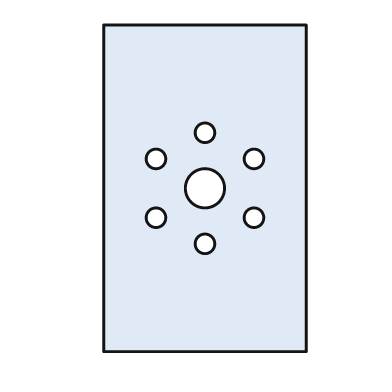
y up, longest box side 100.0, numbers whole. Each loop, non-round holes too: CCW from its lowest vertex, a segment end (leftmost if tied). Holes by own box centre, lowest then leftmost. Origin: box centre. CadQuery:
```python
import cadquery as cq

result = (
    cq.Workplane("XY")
    .moveTo(-31.0, -50.0)
    .lineTo(31.0, -50.0)
    .lineTo(31.0, 50.0)
    .lineTo(-31.0, 50.0)
    .close()
    .moveTo(0.0, -17.0)
    .circle(3.0)
    .moveTo(-15.0, -9.0)
    .circle(3.0)
    .moveTo(15.0, -9.0)
    .circle(3.0)
    .moveTo(0.0, 0.0)
    .circle(6.0)
    .moveTo(-15.0, 9.0)
    .circle(3.0)
    .moveTo(15.0, 9.0)
    .circle(3.0)
    .moveTo(0.0, 17.0)
    .circle(3.0)
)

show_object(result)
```